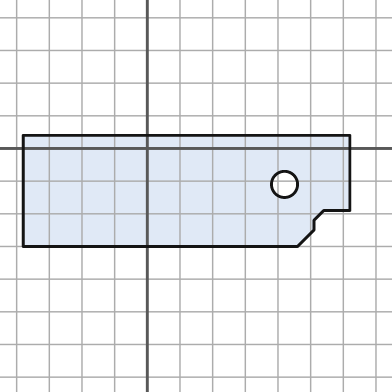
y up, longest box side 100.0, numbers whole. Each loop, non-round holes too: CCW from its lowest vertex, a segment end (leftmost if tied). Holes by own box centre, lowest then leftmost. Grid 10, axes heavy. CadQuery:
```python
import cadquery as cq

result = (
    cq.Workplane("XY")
    .moveTo(-38.0, -30.0)
    .lineTo(46.0, -30.0)
    .lineTo(51.0, -25.0)
    .lineTo(51.0, -22.0)
    .lineTo(54.0, -19.0)
    .lineTo(62.0, -19.0)
    .lineTo(62.0, 4.0)
    .lineTo(-38.0, 4.0)
    .close()
    .moveTo(42.0, -11.0)
    .circle(4.0)
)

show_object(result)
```